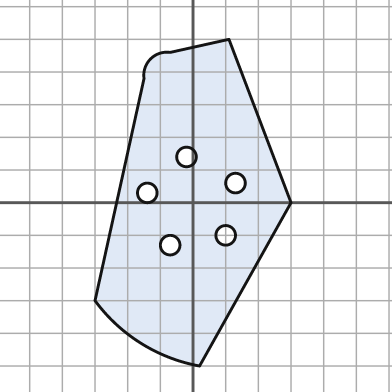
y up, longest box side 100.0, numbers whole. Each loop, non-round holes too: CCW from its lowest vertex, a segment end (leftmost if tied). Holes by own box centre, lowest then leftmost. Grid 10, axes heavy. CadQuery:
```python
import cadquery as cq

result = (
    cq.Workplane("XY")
    .moveTo(2.0, -50.0)
    .lineTo(30.0, 0.0)
    .lineTo(11.0, 50.0)
    .lineTo(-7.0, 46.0)
    .threePointArc((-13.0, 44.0), (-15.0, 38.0))
    .lineTo(-30.0, -30.0)
    .threePointArc((-16.0, -43.0), (2.0, -50.0))
    .close()
    .moveTo(-7.0, -13.0)
    .circle(3.0)
    .moveTo(10.0, -10.0)
    .circle(3.0)
    .moveTo(-14.0, 3.0)
    .circle(3.0)
    .moveTo(13.0, 6.0)
    .circle(3.0)
    .moveTo(-2.0, 14.0)
    .circle(3.0)
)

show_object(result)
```